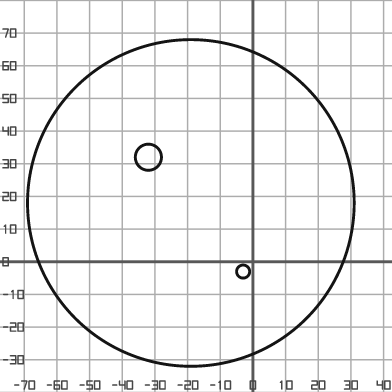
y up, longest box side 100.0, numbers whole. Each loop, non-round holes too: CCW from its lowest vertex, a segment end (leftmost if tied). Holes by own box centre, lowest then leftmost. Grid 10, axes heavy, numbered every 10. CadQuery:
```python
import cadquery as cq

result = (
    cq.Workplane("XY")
    .moveTo(-19.0, 18.0)
    .circle(50.0)
    .moveTo(-3.0, -3.0)
    .circle(2.0)
    .moveTo(-32.0, 32.0)
    .circle(4.0)
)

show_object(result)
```